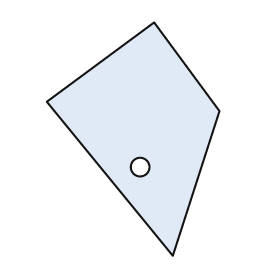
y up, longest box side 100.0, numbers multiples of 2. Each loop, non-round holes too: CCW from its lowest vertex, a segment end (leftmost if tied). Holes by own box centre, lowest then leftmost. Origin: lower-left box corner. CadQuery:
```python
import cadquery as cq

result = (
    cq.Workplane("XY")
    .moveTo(54.0, 0.0)
    .lineTo(74.0, 62.0)
    .lineTo(46.0, 100.0)
    .lineTo(0.0, 66.0)
    .close()
    .moveTo(40.0, 38.0)
    .circle(4.0)
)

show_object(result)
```